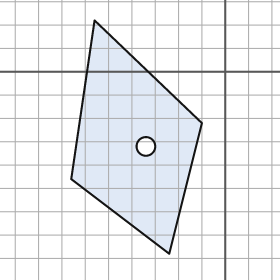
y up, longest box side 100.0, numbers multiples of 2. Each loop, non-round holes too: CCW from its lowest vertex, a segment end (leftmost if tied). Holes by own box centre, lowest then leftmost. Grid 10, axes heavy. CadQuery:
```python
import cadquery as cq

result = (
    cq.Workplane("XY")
    .moveTo(-24.0, -78.0)
    .lineTo(-10.0, -22.0)
    .lineTo(-56.0, 22.0)
    .lineTo(-66.0, -46.0)
    .close()
    .moveTo(-34.0, -32.0)
    .circle(4.0)
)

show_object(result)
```